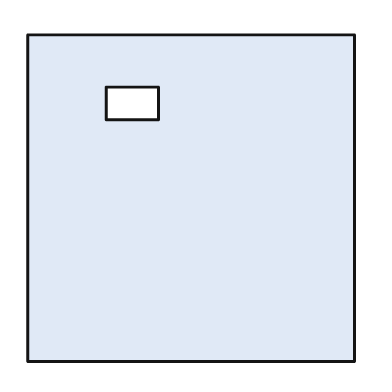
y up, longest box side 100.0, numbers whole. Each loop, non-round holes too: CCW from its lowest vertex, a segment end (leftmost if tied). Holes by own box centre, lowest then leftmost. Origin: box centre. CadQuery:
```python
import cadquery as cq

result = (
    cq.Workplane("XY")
    .moveTo(-50.0, -50.0)
    .lineTo(50.0, -50.0)
    .lineTo(50.0, 50.0)
    .lineTo(-50.0, 50.0)
    .close()
    .moveTo(-26.0, 24.0)
    .lineTo(-10.0, 24.0)
    .lineTo(-10.0, 34.0)
    .lineTo(-26.0, 34.0)
    .close()
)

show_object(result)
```